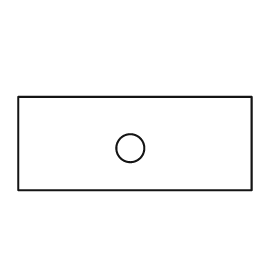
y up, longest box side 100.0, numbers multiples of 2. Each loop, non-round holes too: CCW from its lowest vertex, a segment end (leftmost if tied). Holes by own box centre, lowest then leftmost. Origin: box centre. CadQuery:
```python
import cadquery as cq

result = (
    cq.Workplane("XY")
    .moveTo(-50.0, -20.0)
    .lineTo(50.0, -20.0)
    .lineTo(50.0, 20.0)
    .lineTo(-50.0, 20.0)
    .close()
    .moveTo(-2.0, -2.0)
    .circle(6.0)
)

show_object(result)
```